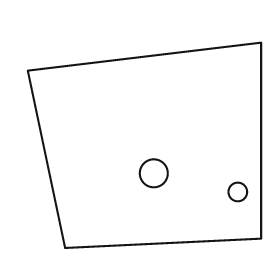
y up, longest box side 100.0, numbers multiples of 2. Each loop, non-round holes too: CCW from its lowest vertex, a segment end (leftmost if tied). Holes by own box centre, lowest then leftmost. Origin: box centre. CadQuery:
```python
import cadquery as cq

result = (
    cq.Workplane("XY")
    .moveTo(-34.0, -44.0)
    .lineTo(50.0, -40.0)
    .lineTo(50.0, 44.0)
    .lineTo(-50.0, 32.0)
    .close()
    .moveTo(40.0, -20.0)
    .circle(4.0)
    .moveTo(4.0, -12.0)
    .circle(6.0)
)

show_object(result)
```